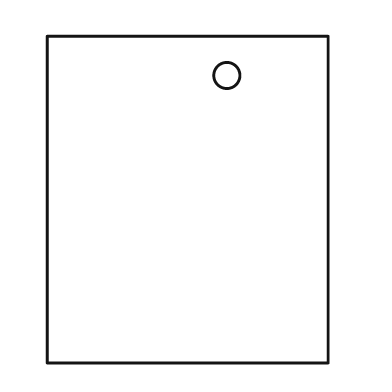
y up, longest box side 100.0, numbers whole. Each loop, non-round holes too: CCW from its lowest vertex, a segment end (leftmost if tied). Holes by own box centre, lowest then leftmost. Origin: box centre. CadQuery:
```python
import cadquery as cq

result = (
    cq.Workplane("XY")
    .moveTo(-43.0, -50.0)
    .lineTo(43.0, -50.0)
    .lineTo(43.0, 50.0)
    .lineTo(-43.0, 50.0)
    .close()
    .moveTo(12.0, 38.0)
    .circle(4.0)
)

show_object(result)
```